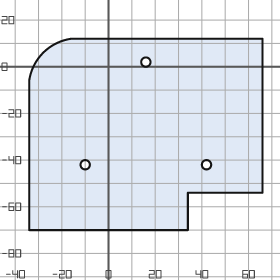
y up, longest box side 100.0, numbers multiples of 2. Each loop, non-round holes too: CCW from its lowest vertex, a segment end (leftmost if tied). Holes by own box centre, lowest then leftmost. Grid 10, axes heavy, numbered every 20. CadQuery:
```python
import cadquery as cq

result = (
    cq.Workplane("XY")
    .moveTo(-34.0, -70.0)
    .lineTo(34.0, -70.0)
    .lineTo(34.0, -54.0)
    .lineTo(66.0, -54.0)
    .lineTo(66.0, 12.0)
    .lineTo(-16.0, 12.0)
    .threePointArc((-28.0, 6.0), (-34.0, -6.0))
    .close()
    .moveTo(-10.0, -42.0)
    .circle(2.0)
    .moveTo(42.0, -42.0)
    .circle(2.0)
    .moveTo(16.0, 2.0)
    .circle(2.0)
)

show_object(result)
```